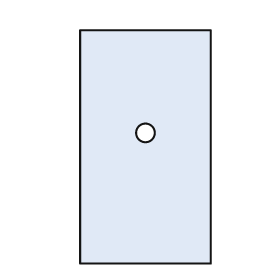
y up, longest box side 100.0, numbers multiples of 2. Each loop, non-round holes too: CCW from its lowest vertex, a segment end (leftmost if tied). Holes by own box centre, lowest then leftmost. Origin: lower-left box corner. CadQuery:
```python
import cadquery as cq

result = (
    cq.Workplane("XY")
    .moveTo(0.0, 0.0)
    .lineTo(56.0, 0.0)
    .lineTo(56.0, 100.0)
    .lineTo(0.0, 100.0)
    .close()
    .moveTo(28.0, 56.0)
    .circle(4.0)
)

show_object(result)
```